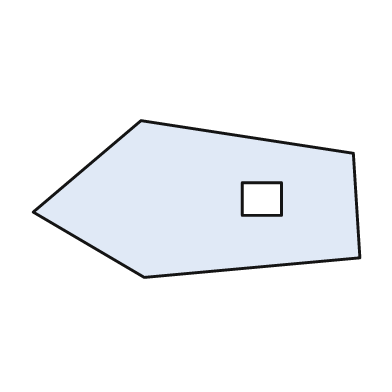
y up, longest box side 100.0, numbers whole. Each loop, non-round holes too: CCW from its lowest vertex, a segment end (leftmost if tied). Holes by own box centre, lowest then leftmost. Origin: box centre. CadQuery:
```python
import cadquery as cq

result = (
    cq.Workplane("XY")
    .moveTo(-16.0, -24.0)
    .lineTo(50.0, -18.0)
    .lineTo(48.0, 14.0)
    .lineTo(-17.0, 24.0)
    .lineTo(-50.0, -4.0)
    .close()
    .moveTo(14.0, -5.0)
    .lineTo(26.0, -5.0)
    .lineTo(26.0, 5.0)
    .lineTo(14.0, 5.0)
    .close()
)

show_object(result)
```